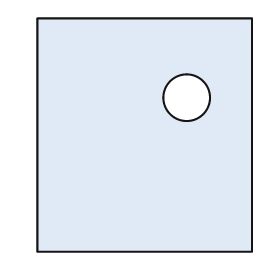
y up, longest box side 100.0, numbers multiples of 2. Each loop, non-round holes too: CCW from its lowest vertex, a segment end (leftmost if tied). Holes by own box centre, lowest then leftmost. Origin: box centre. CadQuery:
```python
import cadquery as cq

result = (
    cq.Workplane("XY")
    .moveTo(-46.0, -50.0)
    .lineTo(46.0, -50.0)
    .lineTo(46.0, 50.0)
    .lineTo(-46.0, 50.0)
    .close()
    .moveTo(18.0, 16.0)
    .circle(10.0)
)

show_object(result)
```